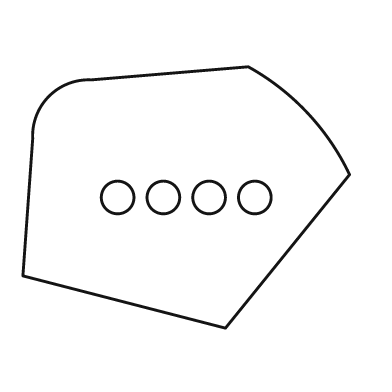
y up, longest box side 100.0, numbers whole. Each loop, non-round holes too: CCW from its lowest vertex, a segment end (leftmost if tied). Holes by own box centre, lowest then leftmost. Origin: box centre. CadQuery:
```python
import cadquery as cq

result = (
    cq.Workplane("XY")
    .moveTo(12.0, -40.0)
    .lineTo(50.0, 7.0)
    .threePointArc((37.0, 26.0), (19.0, 40.0))
    .lineTo(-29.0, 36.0)
    .threePointArc((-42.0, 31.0), (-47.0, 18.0))
    .lineTo(-50.0, -24.0)
    .close()
    .moveTo(-21.0, 0.0)
    .circle(5.0)
    .moveTo(-7.0, 0.0)
    .circle(5.0)
    .moveTo(7.0, 0.0)
    .circle(5.0)
    .moveTo(21.0, 0.0)
    .circle(5.0)
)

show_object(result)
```